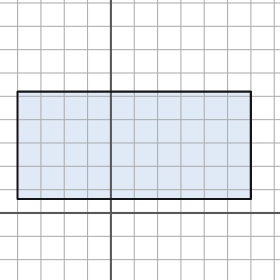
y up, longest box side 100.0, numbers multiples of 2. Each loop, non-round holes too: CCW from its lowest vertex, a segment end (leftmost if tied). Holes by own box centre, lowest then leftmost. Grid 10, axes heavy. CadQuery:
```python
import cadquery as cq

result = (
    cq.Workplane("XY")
    .moveTo(-40.0, 6.0)
    .lineTo(60.0, 6.0)
    .lineTo(60.0, 52.0)
    .lineTo(-40.0, 52.0)
    .close()
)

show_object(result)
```